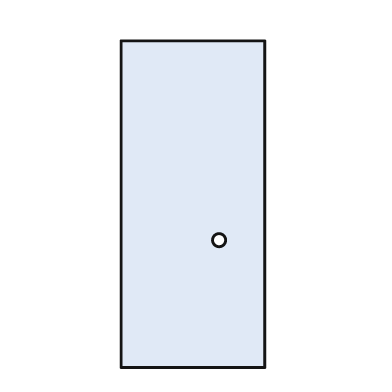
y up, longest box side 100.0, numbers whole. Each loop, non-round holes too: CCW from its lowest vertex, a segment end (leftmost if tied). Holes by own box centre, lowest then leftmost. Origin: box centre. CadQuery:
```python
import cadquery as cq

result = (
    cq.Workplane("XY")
    .moveTo(-22.0, -50.0)
    .lineTo(22.0, -50.0)
    .lineTo(22.0, 50.0)
    .lineTo(-22.0, 50.0)
    .close()
    .moveTo(8.0, -11.0)
    .circle(2.0)
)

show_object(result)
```